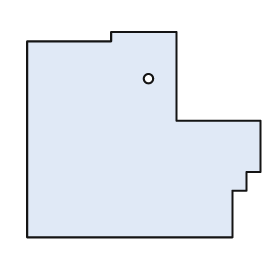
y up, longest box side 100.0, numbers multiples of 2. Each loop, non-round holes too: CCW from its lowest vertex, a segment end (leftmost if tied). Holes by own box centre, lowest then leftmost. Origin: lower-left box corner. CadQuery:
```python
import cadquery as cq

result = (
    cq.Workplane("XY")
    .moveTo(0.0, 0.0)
    .lineTo(88.0, 0.0)
    .lineTo(88.0, 20.0)
    .lineTo(94.0, 20.0)
    .lineTo(94.0, 28.0)
    .lineTo(100.0, 28.0)
    .lineTo(100.0, 50.0)
    .lineTo(64.0, 50.0)
    .lineTo(64.0, 88.0)
    .lineTo(36.0, 88.0)
    .lineTo(36.0, 84.0)
    .lineTo(0.0, 84.0)
    .close()
    .moveTo(52.0, 68.0)
    .circle(2.0)
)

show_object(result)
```